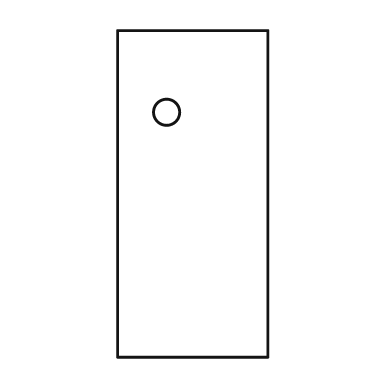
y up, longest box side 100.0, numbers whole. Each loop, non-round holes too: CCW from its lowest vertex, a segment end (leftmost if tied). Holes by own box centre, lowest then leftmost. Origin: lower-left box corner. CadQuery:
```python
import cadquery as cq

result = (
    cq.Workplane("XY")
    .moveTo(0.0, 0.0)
    .lineTo(46.0, 0.0)
    .lineTo(46.0, 100.0)
    .lineTo(0.0, 100.0)
    .close()
    .moveTo(15.0, 75.0)
    .circle(4.0)
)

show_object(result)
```